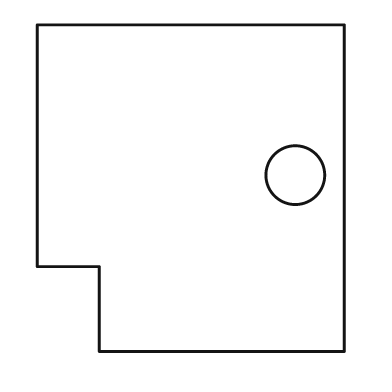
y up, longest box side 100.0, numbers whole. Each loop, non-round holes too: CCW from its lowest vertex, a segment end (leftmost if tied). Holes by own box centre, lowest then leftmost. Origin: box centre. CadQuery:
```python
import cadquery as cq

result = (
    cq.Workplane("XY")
    .moveTo(-28.0, -50.0)
    .lineTo(47.0, -50.0)
    .lineTo(47.0, 50.0)
    .lineTo(-47.0, 50.0)
    .lineTo(-47.0, -24.0)
    .lineTo(-28.0, -24.0)
    .close()
    .moveTo(32.0, 4.0)
    .circle(9.0)
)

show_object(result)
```